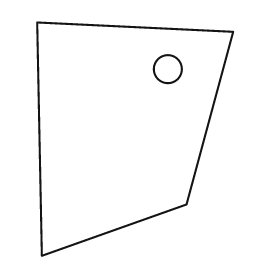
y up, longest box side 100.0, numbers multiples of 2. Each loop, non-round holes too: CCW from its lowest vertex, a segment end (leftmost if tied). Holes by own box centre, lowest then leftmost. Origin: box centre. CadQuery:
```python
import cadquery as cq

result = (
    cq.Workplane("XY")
    .moveTo(-40.0, -50.0)
    .lineTo(22.0, -28.0)
    .lineTo(42.0, 46.0)
    .lineTo(-42.0, 50.0)
    .close()
    .moveTo(14.0, 30.0)
    .circle(6.0)
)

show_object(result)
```